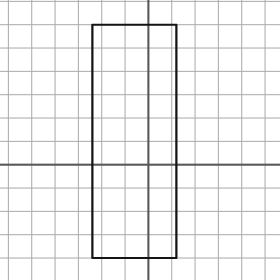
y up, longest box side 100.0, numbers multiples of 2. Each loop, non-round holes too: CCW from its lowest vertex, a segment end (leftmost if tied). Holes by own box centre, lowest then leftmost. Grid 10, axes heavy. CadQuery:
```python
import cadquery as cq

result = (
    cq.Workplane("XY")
    .moveTo(-24.0, -40.0)
    .lineTo(12.0, -40.0)
    .lineTo(12.0, 60.0)
    .lineTo(-24.0, 60.0)
    .close()
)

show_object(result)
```